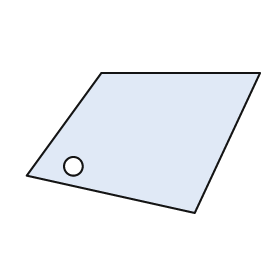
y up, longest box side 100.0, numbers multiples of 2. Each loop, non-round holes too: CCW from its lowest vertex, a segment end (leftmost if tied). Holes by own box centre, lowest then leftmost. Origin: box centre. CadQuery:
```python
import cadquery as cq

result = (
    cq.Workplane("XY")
    .moveTo(22.0, -30.0)
    .lineTo(50.0, 30.0)
    .lineTo(-18.0, 30.0)
    .lineTo(-50.0, -14.0)
    .close()
    .moveTo(-30.0, -10.0)
    .circle(4.0)
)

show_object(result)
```